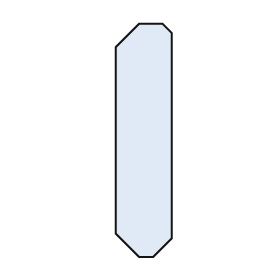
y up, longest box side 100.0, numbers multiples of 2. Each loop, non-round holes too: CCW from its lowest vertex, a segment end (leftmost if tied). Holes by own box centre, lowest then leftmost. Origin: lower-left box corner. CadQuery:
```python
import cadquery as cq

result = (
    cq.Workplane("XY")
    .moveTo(10.0, 0.0)
    .lineTo(16.0, 0.0)
    .lineTo(24.0, 8.0)
    .lineTo(24.0, 96.0)
    .lineTo(20.0, 100.0)
    .lineTo(10.0, 100.0)
    .lineTo(0.0, 90.0)
    .lineTo(0.0, 10.0)
    .close()
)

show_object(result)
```